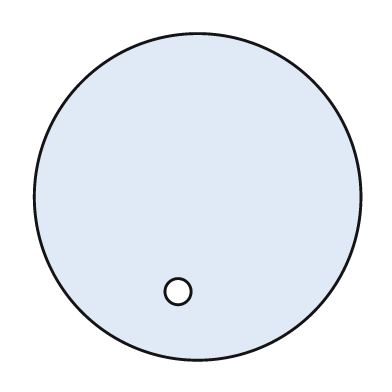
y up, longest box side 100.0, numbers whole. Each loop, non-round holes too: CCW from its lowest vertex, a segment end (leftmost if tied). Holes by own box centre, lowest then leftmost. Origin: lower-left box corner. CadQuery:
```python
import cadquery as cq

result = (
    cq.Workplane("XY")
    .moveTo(50.0, 50.0)
    .circle(50.0)
    .moveTo(44.0, 21.0)
    .circle(4.0)
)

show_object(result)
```